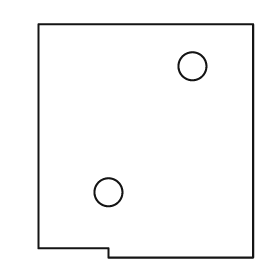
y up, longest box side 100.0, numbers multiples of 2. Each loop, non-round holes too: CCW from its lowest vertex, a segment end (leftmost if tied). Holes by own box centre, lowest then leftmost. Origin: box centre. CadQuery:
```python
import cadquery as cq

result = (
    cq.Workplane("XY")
    .moveTo(-16.0, -50.0)
    .lineTo(46.0, -50.0)
    .lineTo(46.0, 50.0)
    .lineTo(-46.0, 50.0)
    .lineTo(-46.0, -46.0)
    .lineTo(-16.0, -46.0)
    .close()
    .moveTo(-16.0, -22.0)
    .circle(6.0)
    .moveTo(20.0, 32.0)
    .circle(6.0)
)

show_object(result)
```